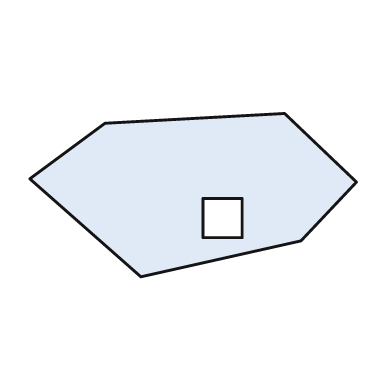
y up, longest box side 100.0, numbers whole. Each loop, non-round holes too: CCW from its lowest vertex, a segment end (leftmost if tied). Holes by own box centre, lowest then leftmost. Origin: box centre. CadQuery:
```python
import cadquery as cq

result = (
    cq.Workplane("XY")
    .moveTo(-16.0, -25.0)
    .lineTo(33.0, -14.0)
    .lineTo(50.0, 4.0)
    .lineTo(28.0, 25.0)
    .lineTo(-27.0, 22.0)
    .lineTo(-50.0, 5.0)
    .close()
    .moveTo(3.0, -13.0)
    .lineTo(15.0, -13.0)
    .lineTo(15.0, -1.0)
    .lineTo(3.0, -1.0)
    .close()
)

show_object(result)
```